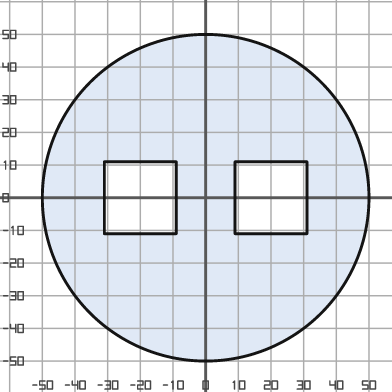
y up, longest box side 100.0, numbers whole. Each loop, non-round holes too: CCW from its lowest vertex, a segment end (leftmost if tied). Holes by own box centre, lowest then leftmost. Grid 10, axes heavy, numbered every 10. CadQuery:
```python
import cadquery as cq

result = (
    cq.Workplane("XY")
    .moveTo(0.0, 0.0)
    .circle(50.0)
    .moveTo(-31.0, -11.0)
    .lineTo(-9.0, -11.0)
    .lineTo(-9.0, 11.0)
    .lineTo(-31.0, 11.0)
    .close()
    .moveTo(9.0, -11.0)
    .lineTo(31.0, -11.0)
    .lineTo(31.0, 11.0)
    .lineTo(9.0, 11.0)
    .close()
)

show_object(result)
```